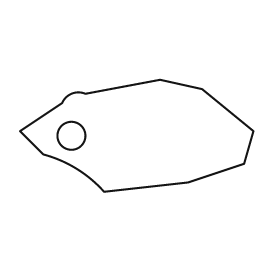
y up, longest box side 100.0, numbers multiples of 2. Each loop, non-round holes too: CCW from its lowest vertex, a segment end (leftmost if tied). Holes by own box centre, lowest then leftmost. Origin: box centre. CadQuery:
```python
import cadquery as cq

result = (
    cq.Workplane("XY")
    .moveTo(-14.0, -24.0)
    .lineTo(22.0, -20.0)
    .lineTo(46.0, -12.0)
    .lineTo(50.0, 2.0)
    .lineTo(28.0, 20.0)
    .lineTo(10.0, 24.0)
    .lineTo(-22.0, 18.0)
    .threePointArc((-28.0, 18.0), (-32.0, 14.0))
    .lineTo(-50.0, 2.0)
    .lineTo(-40.0, -8.0)
    .threePointArc((-26.0, -14.0), (-14.0, -24.0))
    .close()
    .moveTo(-28.0, 0.0)
    .circle(6.0)
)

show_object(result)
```